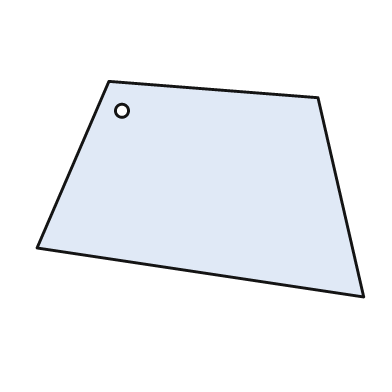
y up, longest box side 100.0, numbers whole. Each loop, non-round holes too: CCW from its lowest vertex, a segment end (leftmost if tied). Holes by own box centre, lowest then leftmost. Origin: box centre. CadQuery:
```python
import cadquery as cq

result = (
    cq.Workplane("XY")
    .moveTo(50.0, -33.0)
    .lineTo(36.0, 28.0)
    .lineTo(-28.0, 33.0)
    .lineTo(-50.0, -18.0)
    .close()
    .moveTo(-24.0, 24.0)
    .circle(2.0)
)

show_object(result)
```